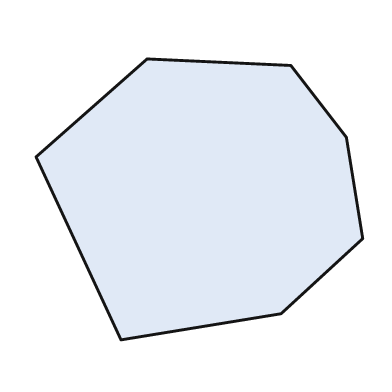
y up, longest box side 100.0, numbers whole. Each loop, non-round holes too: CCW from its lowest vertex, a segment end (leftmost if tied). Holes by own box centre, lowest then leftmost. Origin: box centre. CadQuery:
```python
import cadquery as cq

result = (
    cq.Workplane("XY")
    .moveTo(-24.0, -43.0)
    .lineTo(25.0, -35.0)
    .lineTo(50.0, -12.0)
    .lineTo(45.0, 19.0)
    .lineTo(28.0, 41.0)
    .lineTo(-16.0, 43.0)
    .lineTo(-50.0, 13.0)
    .close()
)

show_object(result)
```